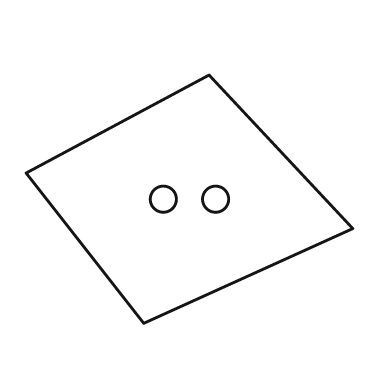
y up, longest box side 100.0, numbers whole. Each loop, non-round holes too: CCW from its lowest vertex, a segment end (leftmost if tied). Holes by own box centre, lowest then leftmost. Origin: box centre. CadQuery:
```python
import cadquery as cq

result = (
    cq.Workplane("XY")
    .moveTo(-14.0, -38.0)
    .lineTo(50.0, -9.0)
    .lineTo(6.0, 38.0)
    .lineTo(-50.0, 8.0)
    .close()
    .moveTo(-8.0, 0.0)
    .circle(4.0)
    .moveTo(8.0, 0.0)
    .circle(4.0)
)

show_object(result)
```